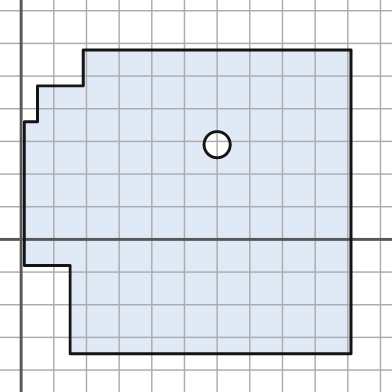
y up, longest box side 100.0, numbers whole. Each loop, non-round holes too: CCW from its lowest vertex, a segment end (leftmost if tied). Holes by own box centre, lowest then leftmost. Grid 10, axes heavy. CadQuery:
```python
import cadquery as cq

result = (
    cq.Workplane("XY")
    .moveTo(15.0, -35.0)
    .lineTo(101.0, -35.0)
    .lineTo(101.0, 58.0)
    .lineTo(19.0, 58.0)
    .lineTo(19.0, 47.0)
    .lineTo(5.0, 47.0)
    .lineTo(5.0, 36.0)
    .lineTo(1.0, 36.0)
    .lineTo(1.0, -8.0)
    .lineTo(15.0, -8.0)
    .close()
    .moveTo(60.0, 29.0)
    .circle(4.0)
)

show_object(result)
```